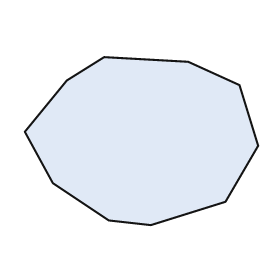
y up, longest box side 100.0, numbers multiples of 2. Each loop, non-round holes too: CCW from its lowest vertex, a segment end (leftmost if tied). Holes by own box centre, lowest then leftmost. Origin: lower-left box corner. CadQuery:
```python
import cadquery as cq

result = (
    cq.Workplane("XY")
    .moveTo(54.0, 0.0)
    .lineTo(86.0, 10.0)
    .lineTo(100.0, 34.0)
    .lineTo(92.0, 60.0)
    .lineTo(70.0, 70.0)
    .lineTo(34.0, 72.0)
    .lineTo(18.0, 62.0)
    .lineTo(0.0, 40.0)
    .lineTo(12.0, 18.0)
    .lineTo(36.0, 2.0)
    .close()
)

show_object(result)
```